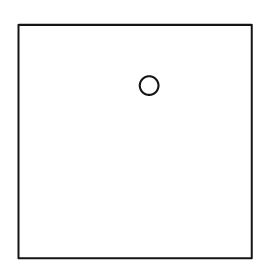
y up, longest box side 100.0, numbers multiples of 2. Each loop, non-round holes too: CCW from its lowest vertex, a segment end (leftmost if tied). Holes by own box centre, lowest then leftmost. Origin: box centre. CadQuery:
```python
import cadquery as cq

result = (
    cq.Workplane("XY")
    .moveTo(-50.0, -50.0)
    .lineTo(50.0, -50.0)
    .lineTo(50.0, 50.0)
    .lineTo(-50.0, 50.0)
    .close()
    .moveTo(6.0, 24.0)
    .circle(4.0)
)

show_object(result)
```